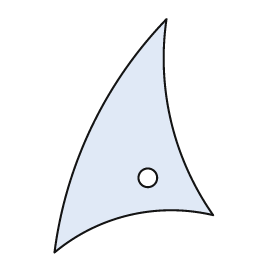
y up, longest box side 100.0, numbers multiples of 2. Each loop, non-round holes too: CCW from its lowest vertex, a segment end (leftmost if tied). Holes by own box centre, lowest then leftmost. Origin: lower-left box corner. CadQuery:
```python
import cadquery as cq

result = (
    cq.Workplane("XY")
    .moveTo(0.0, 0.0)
    .threePointArc((32.0, 16.0), (68.0, 16.0))
    .threePointArc((50.0, 56.0), (48.0, 100.0))
    .threePointArc((16.0, 54.0), (0.0, 0.0))
    .close()
    .moveTo(40.0, 32.0)
    .circle(4.0)
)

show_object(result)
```